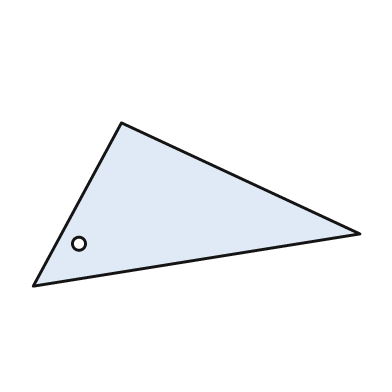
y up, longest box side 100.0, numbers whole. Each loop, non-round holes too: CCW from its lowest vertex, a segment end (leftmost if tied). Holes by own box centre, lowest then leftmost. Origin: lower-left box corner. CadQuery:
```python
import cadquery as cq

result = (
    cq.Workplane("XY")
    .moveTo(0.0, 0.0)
    .lineTo(100.0, 16.0)
    .lineTo(27.0, 50.0)
    .close()
    .moveTo(14.0, 13.0)
    .circle(2.0)
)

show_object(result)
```